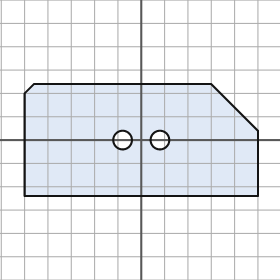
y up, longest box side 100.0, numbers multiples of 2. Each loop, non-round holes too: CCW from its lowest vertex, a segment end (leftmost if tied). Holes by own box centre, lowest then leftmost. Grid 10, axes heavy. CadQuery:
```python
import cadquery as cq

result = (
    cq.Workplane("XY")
    .moveTo(-50.0, -24.0)
    .lineTo(50.0, -24.0)
    .lineTo(50.0, 4.0)
    .lineTo(30.0, 24.0)
    .lineTo(-46.0, 24.0)
    .lineTo(-50.0, 20.0)
    .close()
    .moveTo(-8.0, 0.0)
    .circle(4.0)
    .moveTo(8.0, 0.0)
    .circle(4.0)
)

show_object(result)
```